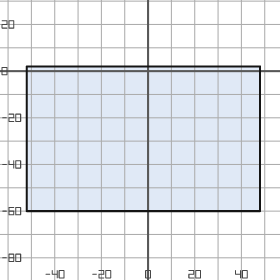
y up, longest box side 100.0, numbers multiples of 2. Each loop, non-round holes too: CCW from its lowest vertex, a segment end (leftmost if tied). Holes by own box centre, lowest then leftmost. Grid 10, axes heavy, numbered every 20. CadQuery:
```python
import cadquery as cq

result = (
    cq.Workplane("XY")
    .moveTo(-52.0, -60.0)
    .lineTo(48.0, -60.0)
    .lineTo(48.0, 2.0)
    .lineTo(-52.0, 2.0)
    .close()
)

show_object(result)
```